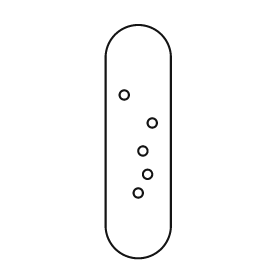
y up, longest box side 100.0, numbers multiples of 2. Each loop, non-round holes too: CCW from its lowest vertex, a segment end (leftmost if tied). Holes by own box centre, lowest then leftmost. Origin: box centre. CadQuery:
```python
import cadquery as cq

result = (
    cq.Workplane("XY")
    .moveTo(-14.0, -36.0)
    .threePointArc((0.0, -50.0), (14.0, -36.0))
    .lineTo(14.0, 36.0)
    .threePointArc((0.0, 50.0), (-14.0, 36.0))
    .close()
    .moveTo(0.0, -22.0)
    .circle(2.0)
    .moveTo(4.0, -14.0)
    .circle(2.0)
    .moveTo(2.0, -4.0)
    .circle(2.0)
    .moveTo(6.0, 8.0)
    .circle(2.0)
    .moveTo(-6.0, 20.0)
    .circle(2.0)
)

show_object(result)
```